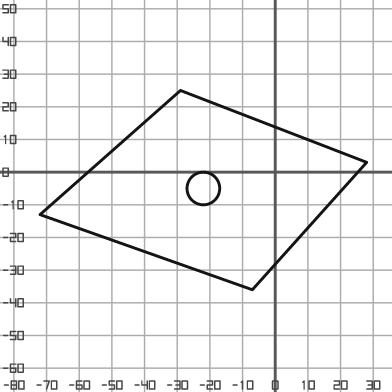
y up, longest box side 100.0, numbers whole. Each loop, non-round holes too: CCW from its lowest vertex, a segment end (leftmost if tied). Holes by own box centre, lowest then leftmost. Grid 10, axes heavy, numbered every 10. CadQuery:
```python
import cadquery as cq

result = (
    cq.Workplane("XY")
    .moveTo(-7.0, -36.0)
    .lineTo(28.0, 3.0)
    .lineTo(-29.0, 25.0)
    .lineTo(-72.0, -13.0)
    .close()
    .moveTo(-22.0, -5.0)
    .circle(5.0)
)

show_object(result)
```